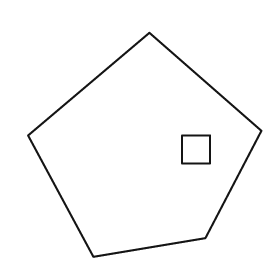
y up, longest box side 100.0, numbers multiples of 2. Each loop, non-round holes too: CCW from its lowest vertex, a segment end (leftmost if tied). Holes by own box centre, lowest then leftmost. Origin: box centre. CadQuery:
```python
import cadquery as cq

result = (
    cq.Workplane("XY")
    .moveTo(-22.0, -48.0)
    .lineTo(26.0, -40.0)
    .lineTo(50.0, 6.0)
    .lineTo(2.0, 48.0)
    .lineTo(-50.0, 4.0)
    .close()
    .moveTo(16.0, -8.0)
    .lineTo(28.0, -8.0)
    .lineTo(28.0, 4.0)
    .lineTo(16.0, 4.0)
    .close()
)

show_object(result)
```